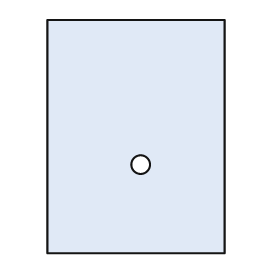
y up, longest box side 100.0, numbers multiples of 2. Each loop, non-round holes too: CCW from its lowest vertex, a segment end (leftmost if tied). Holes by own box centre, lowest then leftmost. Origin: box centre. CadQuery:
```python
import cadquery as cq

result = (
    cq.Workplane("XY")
    .moveTo(-38.0, -50.0)
    .lineTo(38.0, -50.0)
    .lineTo(38.0, 50.0)
    .lineTo(-38.0, 50.0)
    .close()
    .moveTo(2.0, -12.0)
    .circle(4.0)
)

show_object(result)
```